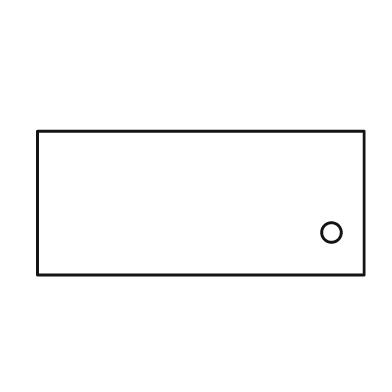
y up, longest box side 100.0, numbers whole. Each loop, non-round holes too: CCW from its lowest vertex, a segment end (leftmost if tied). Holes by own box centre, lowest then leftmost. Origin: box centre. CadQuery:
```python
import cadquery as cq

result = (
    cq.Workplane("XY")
    .moveTo(-50.0, -22.0)
    .lineTo(50.0, -22.0)
    .lineTo(50.0, 22.0)
    .lineTo(-50.0, 22.0)
    .close()
    .moveTo(40.0, -9.0)
    .circle(3.0)
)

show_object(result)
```